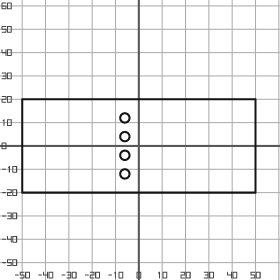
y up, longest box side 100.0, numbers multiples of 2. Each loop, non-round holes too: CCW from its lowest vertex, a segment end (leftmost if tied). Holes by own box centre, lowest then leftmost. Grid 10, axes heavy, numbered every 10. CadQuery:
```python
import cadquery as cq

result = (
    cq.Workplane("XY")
    .moveTo(-50.0, -20.0)
    .lineTo(50.0, -20.0)
    .lineTo(50.0, 20.0)
    .lineTo(-50.0, 20.0)
    .close()
    .moveTo(-6.0, -12.0)
    .circle(2.0)
    .moveTo(-6.0, -4.0)
    .circle(2.0)
    .moveTo(-6.0, 4.0)
    .circle(2.0)
    .moveTo(-6.0, 12.0)
    .circle(2.0)
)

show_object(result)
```